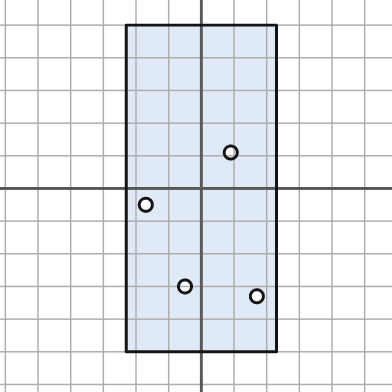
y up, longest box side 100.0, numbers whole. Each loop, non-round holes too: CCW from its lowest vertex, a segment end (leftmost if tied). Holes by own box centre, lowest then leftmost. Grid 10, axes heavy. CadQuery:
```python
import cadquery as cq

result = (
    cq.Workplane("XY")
    .moveTo(-23.0, -50.0)
    .lineTo(23.0, -50.0)
    .lineTo(23.0, 50.0)
    .lineTo(-23.0, 50.0)
    .close()
    .moveTo(17.0, -33.0)
    .circle(2.0)
    .moveTo(-5.0, -30.0)
    .circle(2.0)
    .moveTo(-17.0, -5.0)
    .circle(2.0)
    .moveTo(9.0, 11.0)
    .circle(2.0)
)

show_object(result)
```